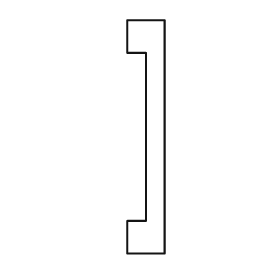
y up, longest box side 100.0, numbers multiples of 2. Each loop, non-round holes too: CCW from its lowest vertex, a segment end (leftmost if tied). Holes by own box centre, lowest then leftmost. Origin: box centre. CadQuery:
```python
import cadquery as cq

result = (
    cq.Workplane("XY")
    .moveTo(-8.0, -50.0)
    .lineTo(8.0, -50.0)
    .lineTo(8.0, 50.0)
    .lineTo(-8.0, 50.0)
    .lineTo(-8.0, 36.0)
    .lineTo(0.0, 36.0)
    .lineTo(0.0, -36.0)
    .lineTo(-8.0, -36.0)
    .close()
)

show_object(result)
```